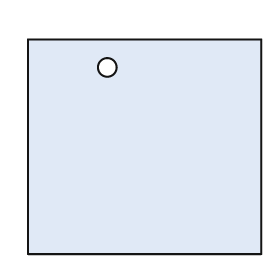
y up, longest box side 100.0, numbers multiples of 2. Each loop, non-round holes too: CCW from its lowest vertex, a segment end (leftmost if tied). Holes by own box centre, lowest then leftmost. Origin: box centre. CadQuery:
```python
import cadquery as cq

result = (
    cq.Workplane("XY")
    .moveTo(-50.0, -46.0)
    .lineTo(50.0, -46.0)
    .lineTo(50.0, 46.0)
    .lineTo(-50.0, 46.0)
    .close()
    .moveTo(-16.0, 34.0)
    .circle(4.0)
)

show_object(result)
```